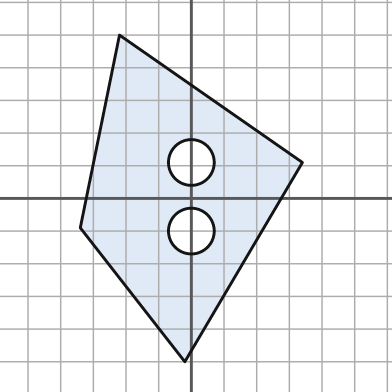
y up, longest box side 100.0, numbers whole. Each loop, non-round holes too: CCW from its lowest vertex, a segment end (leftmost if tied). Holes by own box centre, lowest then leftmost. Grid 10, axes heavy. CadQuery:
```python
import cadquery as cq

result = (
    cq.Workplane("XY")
    .moveTo(-2.0, -50.0)
    .lineTo(34.0, 11.0)
    .lineTo(-22.0, 50.0)
    .lineTo(-34.0, -9.0)
    .close()
    .moveTo(0.0, -10.0)
    .circle(7.0)
    .moveTo(0.0, 11.0)
    .circle(7.0)
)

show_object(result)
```